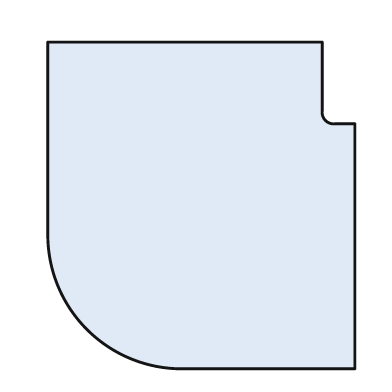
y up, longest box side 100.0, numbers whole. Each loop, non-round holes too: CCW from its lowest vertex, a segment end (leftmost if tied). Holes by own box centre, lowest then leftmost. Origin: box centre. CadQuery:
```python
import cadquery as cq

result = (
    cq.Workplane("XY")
    .moveTo(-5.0, -50.0)
    .lineTo(47.0, -50.0)
    .lineTo(47.0, 25.0)
    .lineTo(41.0, 25.0)
    .threePointArc((38.0, 26.0), (37.0, 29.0))
    .lineTo(37.0, 50.0)
    .lineTo(-47.0, 50.0)
    .lineTo(-47.0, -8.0)
    .threePointArc((-35.0, -38.0), (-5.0, -50.0))
    .close()
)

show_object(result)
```